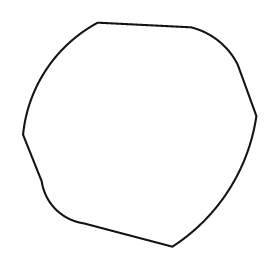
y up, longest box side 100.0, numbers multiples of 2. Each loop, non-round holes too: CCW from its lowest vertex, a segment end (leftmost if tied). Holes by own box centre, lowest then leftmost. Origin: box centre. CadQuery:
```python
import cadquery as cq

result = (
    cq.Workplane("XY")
    .moveTo(14.0, -48.0)
    .threePointArc((38.0, -24.0), (50.0, 8.0))
    .lineTo(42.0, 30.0)
    .threePointArc((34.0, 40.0), (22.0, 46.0))
    .lineTo(-18.0, 48.0)
    .threePointArc((-40.0, 28.0), (-50.0, 0.0))
    .lineTo(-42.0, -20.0)
    .threePointArc((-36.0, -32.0), (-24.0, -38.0))
    .close()
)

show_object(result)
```